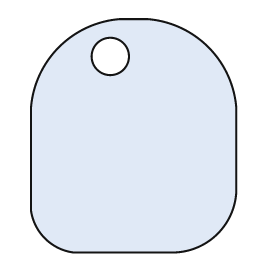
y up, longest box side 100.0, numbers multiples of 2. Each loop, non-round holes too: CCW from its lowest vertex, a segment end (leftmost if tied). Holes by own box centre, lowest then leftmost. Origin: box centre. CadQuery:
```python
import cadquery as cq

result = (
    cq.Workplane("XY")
    .moveTo(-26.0, -50.0)
    .lineTo(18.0, -50.0)
    .threePointArc((36.0, -42.0), (44.0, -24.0))
    .lineTo(44.0, 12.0)
    .threePointArc((32.0, 38.0), (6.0, 50.0))
    .lineTo(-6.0, 50.0)
    .threePointArc((-32.0, 38.0), (-44.0, 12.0))
    .lineTo(-44.0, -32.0)
    .threePointArc((-38.0, -44.0), (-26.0, -50.0))
    .close()
    .moveTo(-10.0, 34.0)
    .circle(8.0)
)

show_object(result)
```